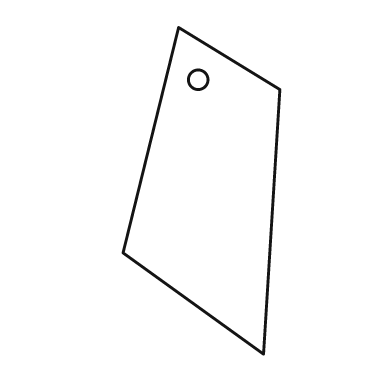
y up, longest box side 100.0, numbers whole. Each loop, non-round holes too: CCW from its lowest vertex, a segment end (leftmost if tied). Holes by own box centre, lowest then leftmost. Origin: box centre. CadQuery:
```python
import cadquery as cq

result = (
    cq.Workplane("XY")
    .moveTo(19.0, -50.0)
    .lineTo(24.0, 31.0)
    .lineTo(-7.0, 50.0)
    .lineTo(-24.0, -19.0)
    .close()
    .moveTo(-1.0, 34.0)
    .circle(3.0)
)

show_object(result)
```